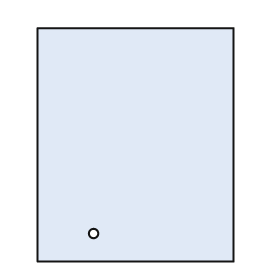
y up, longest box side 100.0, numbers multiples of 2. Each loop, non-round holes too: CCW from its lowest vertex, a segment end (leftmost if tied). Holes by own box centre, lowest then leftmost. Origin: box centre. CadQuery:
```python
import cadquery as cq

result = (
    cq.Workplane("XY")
    .moveTo(-42.0, -50.0)
    .lineTo(42.0, -50.0)
    .lineTo(42.0, 50.0)
    .lineTo(-42.0, 50.0)
    .close()
    .moveTo(-18.0, -38.0)
    .circle(2.0)
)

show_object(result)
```